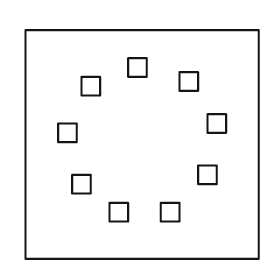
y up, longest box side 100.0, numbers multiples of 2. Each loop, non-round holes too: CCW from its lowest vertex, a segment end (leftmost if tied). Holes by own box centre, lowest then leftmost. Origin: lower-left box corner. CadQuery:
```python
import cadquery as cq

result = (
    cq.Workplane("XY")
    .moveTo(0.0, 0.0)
    .lineTo(100.0, 0.0)
    .lineTo(100.0, 98.0)
    .lineTo(0.0, 98.0)
    .close()
    .moveTo(36.0, 16.0)
    .lineTo(44.0, 16.0)
    .lineTo(44.0, 24.0)
    .lineTo(36.0, 24.0)
    .close()
    .moveTo(58.0, 16.0)
    .lineTo(66.0, 16.0)
    .lineTo(66.0, 24.0)
    .lineTo(58.0, 24.0)
    .close()
    .moveTo(20.0, 28.0)
    .lineTo(28.0, 28.0)
    .lineTo(28.0, 36.0)
    .lineTo(20.0, 36.0)
    .close()
    .moveTo(74.0, 32.0)
    .lineTo(82.0, 32.0)
    .lineTo(82.0, 40.0)
    .lineTo(74.0, 40.0)
    .close()
    .moveTo(14.0, 50.0)
    .lineTo(22.0, 50.0)
    .lineTo(22.0, 58.0)
    .lineTo(14.0, 58.0)
    .close()
    .moveTo(78.0, 54.0)
    .lineTo(86.0, 54.0)
    .lineTo(86.0, 62.0)
    .lineTo(78.0, 62.0)
    .close()
    .moveTo(24.0, 70.0)
    .lineTo(32.0, 70.0)
    .lineTo(32.0, 78.0)
    .lineTo(24.0, 78.0)
    .close()
    .moveTo(66.0, 72.0)
    .lineTo(74.0, 72.0)
    .lineTo(74.0, 80.0)
    .lineTo(66.0, 80.0)
    .close()
    .moveTo(44.0, 78.0)
    .lineTo(52.0, 78.0)
    .lineTo(52.0, 86.0)
    .lineTo(44.0, 86.0)
    .close()
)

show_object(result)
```